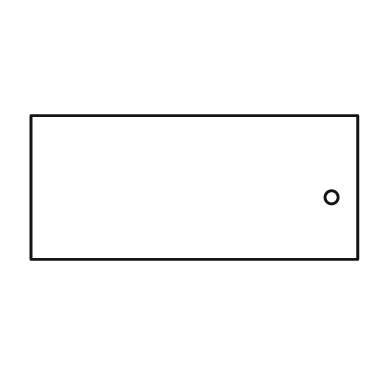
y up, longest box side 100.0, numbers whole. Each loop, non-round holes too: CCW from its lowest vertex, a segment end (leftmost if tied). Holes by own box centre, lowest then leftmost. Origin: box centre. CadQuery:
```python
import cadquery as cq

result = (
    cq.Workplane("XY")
    .moveTo(-50.0, -22.0)
    .lineTo(50.0, -22.0)
    .lineTo(50.0, 22.0)
    .lineTo(-50.0, 22.0)
    .close()
    .moveTo(42.0, -3.0)
    .circle(2.0)
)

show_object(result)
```